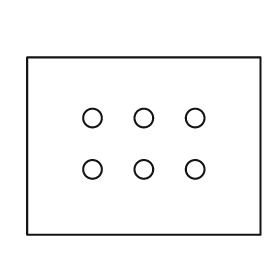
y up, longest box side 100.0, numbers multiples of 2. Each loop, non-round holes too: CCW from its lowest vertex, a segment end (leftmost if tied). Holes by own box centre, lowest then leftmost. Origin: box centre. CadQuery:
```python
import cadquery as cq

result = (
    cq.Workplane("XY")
    .moveTo(-50.0, -38.0)
    .lineTo(50.0, -38.0)
    .lineTo(50.0, 38.0)
    .lineTo(-50.0, 38.0)
    .close()
    .moveTo(-22.0, -10.0)
    .circle(4.0)
    .moveTo(0.0, -10.0)
    .circle(4.0)
    .moveTo(22.0, -10.0)
    .circle(4.0)
    .moveTo(-22.0, 12.0)
    .circle(4.0)
    .moveTo(0.0, 12.0)
    .circle(4.0)
    .moveTo(22.0, 12.0)
    .circle(4.0)
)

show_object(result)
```